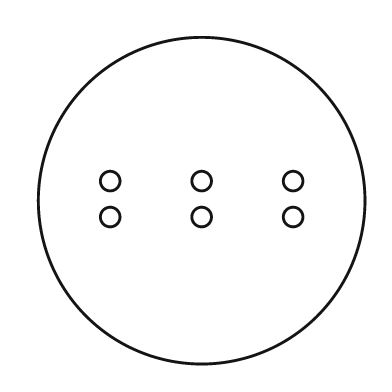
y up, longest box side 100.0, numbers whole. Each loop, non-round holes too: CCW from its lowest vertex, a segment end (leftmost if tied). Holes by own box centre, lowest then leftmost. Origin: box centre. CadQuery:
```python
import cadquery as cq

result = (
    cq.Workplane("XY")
    .moveTo(0.0, 0.0)
    .circle(50.0)
    .moveTo(-28.0, -5.0)
    .circle(3.0)
    .moveTo(0.0, -5.0)
    .circle(3.0)
    .moveTo(28.0, -5.0)
    .circle(3.0)
    .moveTo(-28.0, 6.0)
    .circle(3.0)
    .moveTo(0.0, 6.0)
    .circle(3.0)
    .moveTo(28.0, 6.0)
    .circle(3.0)
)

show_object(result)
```